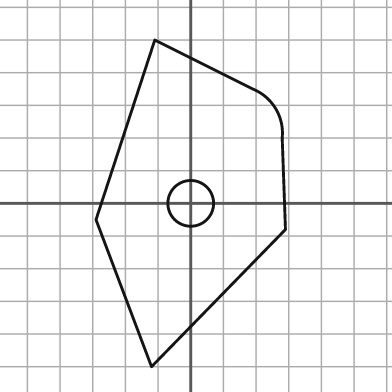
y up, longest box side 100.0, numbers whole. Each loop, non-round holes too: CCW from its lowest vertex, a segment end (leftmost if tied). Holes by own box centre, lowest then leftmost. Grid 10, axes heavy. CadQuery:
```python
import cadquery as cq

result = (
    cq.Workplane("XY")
    .moveTo(-12.0, -50.0)
    .lineTo(29.0, -8.0)
    .lineTo(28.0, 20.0)
    .threePointArc((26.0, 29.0), (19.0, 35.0))
    .lineTo(-11.0, 50.0)
    .lineTo(-29.0, -5.0)
    .close()
    .moveTo(0.0, 0.0)
    .circle(7.0)
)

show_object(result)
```